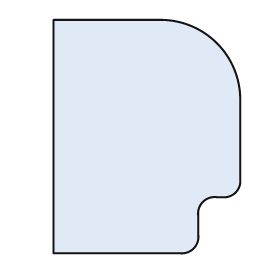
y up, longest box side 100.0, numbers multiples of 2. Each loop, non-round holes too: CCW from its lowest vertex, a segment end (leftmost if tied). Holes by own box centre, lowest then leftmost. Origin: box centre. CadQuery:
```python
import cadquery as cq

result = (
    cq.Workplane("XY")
    .moveTo(-40.0, -50.0)
    .lineTo(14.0, -50.0)
    .threePointArc((20.0, -48.0), (22.0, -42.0))
    .lineTo(22.0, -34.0)
    .threePointArc((24.0, -28.0), (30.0, -26.0))
    .lineTo(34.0, -26.0)
    .threePointArc((38.0, -24.0), (40.0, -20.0))
    .lineTo(40.0, 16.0)
    .threePointArc((30.0, 40.0), (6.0, 50.0))
    .lineTo(-40.0, 50.0)
    .close()
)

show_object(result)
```